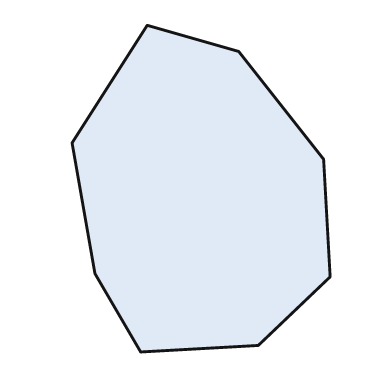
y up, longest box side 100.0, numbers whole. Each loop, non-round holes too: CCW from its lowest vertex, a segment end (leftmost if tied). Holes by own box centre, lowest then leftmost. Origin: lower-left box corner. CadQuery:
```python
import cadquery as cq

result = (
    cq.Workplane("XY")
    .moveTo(21.0, 0.0)
    .lineTo(57.0, 2.0)
    .lineTo(79.0, 23.0)
    .lineTo(77.0, 59.0)
    .lineTo(51.0, 92.0)
    .lineTo(23.0, 100.0)
    .lineTo(0.0, 64.0)
    .lineTo(7.0, 24.0)
    .close()
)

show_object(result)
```